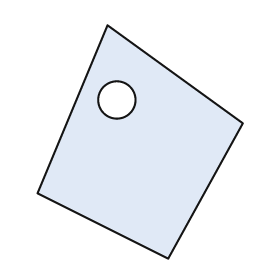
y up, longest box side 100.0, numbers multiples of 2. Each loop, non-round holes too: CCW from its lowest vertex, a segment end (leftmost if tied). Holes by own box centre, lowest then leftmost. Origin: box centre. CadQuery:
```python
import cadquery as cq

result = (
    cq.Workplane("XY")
    .moveTo(12.0, -50.0)
    .lineTo(44.0, 8.0)
    .lineTo(-14.0, 50.0)
    .lineTo(-44.0, -22.0)
    .close()
    .moveTo(-10.0, 18.0)
    .circle(8.0)
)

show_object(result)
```